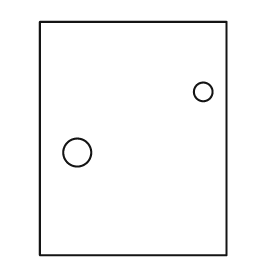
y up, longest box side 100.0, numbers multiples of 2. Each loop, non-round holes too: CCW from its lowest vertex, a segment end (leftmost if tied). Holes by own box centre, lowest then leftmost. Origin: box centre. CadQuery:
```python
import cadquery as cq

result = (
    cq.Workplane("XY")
    .moveTo(-40.0, -50.0)
    .lineTo(40.0, -50.0)
    .lineTo(40.0, 50.0)
    .lineTo(-40.0, 50.0)
    .close()
    .moveTo(-24.0, -6.0)
    .circle(6.0)
    .moveTo(30.0, 20.0)
    .circle(4.0)
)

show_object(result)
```